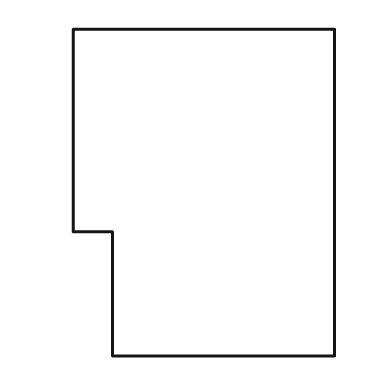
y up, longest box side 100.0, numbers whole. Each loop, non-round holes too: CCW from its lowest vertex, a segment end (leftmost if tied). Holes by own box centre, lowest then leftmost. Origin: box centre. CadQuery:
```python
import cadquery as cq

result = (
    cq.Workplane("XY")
    .moveTo(-28.0, -50.0)
    .lineTo(40.0, -50.0)
    .lineTo(40.0, 50.0)
    .lineTo(-40.0, 50.0)
    .lineTo(-40.0, -12.0)
    .lineTo(-28.0, -12.0)
    .close()
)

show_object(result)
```